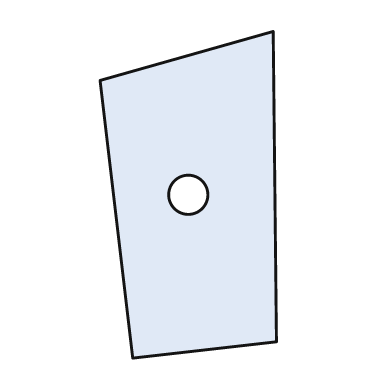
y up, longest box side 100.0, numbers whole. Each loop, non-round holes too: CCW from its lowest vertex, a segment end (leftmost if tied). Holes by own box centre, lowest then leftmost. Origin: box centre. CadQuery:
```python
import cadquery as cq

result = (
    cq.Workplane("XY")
    .moveTo(-17.0, -50.0)
    .lineTo(27.0, -45.0)
    .lineTo(26.0, 50.0)
    .lineTo(-27.0, 35.0)
    .close()
    .moveTo(0.0, 0.0)
    .circle(6.0)
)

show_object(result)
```